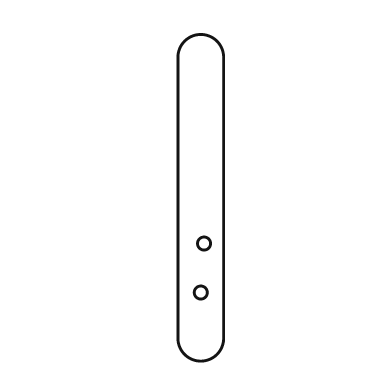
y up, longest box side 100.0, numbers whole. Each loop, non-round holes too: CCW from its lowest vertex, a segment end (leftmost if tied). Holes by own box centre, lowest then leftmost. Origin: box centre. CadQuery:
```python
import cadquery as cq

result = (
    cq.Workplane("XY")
    .moveTo(-7.0, -43.0)
    .threePointArc((0.0, -50.0), (7.0, -43.0))
    .lineTo(7.0, 43.0)
    .threePointArc((0.0, 50.0), (-7.0, 43.0))
    .close()
    .moveTo(0.0, -29.0)
    .circle(2.0)
    .moveTo(1.0, -14.0)
    .circle(2.0)
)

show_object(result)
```